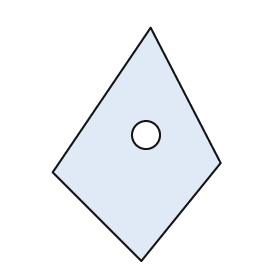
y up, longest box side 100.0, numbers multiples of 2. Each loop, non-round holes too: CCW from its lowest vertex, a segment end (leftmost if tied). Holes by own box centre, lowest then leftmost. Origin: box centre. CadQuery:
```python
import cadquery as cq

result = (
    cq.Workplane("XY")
    .moveTo(2.0, -50.0)
    .lineTo(36.0, -8.0)
    .lineTo(6.0, 50.0)
    .lineTo(-36.0, -12.0)
    .close()
    .moveTo(4.0, 4.0)
    .circle(6.0)
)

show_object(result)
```